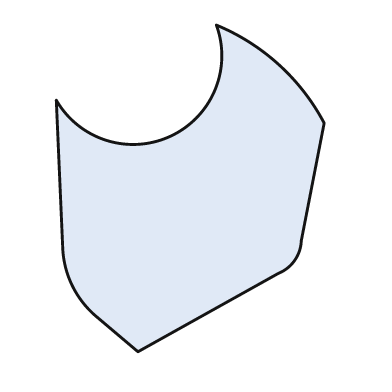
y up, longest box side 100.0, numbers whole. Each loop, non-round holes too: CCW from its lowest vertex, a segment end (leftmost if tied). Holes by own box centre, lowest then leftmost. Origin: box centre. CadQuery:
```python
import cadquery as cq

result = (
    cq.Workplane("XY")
    .moveTo(-16.0, -50.0)
    .lineTo(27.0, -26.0)
    .threePointArc((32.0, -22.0), (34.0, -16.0))
    .lineTo(41.0, 20.0)
    .threePointArc((27.0, 38.0), (8.0, 50.0))
    .threePointArc((-6.0, 16.0), (-41.0, 27.0))
    .lineTo(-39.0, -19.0)
    .threePointArc((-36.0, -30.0), (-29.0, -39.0))
    .close()
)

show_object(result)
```